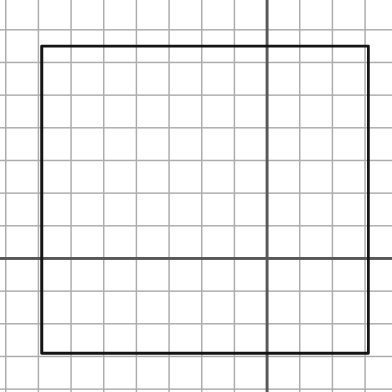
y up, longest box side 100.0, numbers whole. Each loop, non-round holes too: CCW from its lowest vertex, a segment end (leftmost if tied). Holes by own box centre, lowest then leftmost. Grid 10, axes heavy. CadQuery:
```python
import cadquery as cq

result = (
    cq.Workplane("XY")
    .moveTo(-69.0, -29.0)
    .lineTo(31.0, -29.0)
    .lineTo(31.0, 65.0)
    .lineTo(-69.0, 65.0)
    .close()
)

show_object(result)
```